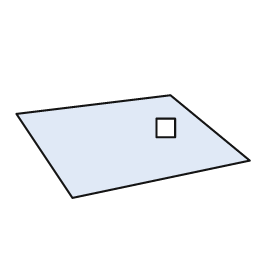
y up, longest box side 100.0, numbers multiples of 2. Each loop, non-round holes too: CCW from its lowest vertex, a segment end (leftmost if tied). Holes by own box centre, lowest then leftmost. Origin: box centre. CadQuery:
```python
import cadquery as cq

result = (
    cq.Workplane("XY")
    .moveTo(-26.0, -22.0)
    .lineTo(50.0, -6.0)
    .lineTo(16.0, 22.0)
    .lineTo(-50.0, 14.0)
    .close()
    .moveTo(10.0, 4.0)
    .lineTo(18.0, 4.0)
    .lineTo(18.0, 12.0)
    .lineTo(10.0, 12.0)
    .close()
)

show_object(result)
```